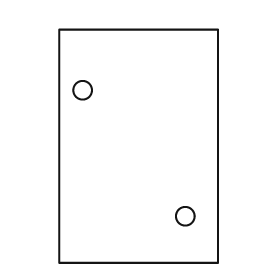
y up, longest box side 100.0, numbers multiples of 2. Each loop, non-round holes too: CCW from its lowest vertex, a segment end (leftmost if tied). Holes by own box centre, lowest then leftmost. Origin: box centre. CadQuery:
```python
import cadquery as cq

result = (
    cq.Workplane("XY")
    .moveTo(-34.0, -50.0)
    .lineTo(34.0, -50.0)
    .lineTo(34.0, 50.0)
    .lineTo(-34.0, 50.0)
    .close()
    .moveTo(20.0, -30.0)
    .circle(4.0)
    .moveTo(-24.0, 24.0)
    .circle(4.0)
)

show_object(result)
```